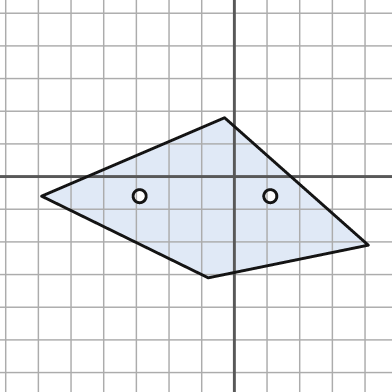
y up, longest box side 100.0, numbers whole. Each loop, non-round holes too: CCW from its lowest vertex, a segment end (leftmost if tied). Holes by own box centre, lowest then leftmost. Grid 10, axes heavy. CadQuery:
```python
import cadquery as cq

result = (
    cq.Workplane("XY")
    .moveTo(-8.0, -31.0)
    .lineTo(41.0, -21.0)
    .lineTo(-3.0, 18.0)
    .lineTo(-59.0, -6.0)
    .close()
    .moveTo(-29.0, -6.0)
    .circle(2.0)
    .moveTo(11.0, -6.0)
    .circle(2.0)
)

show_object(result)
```